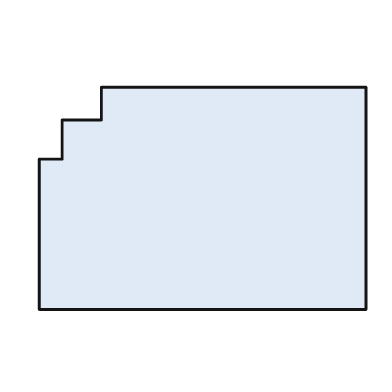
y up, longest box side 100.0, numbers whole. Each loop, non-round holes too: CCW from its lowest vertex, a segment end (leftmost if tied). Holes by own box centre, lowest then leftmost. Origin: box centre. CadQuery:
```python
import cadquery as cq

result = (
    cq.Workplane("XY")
    .moveTo(-50.0, -34.0)
    .lineTo(50.0, -34.0)
    .lineTo(50.0, 34.0)
    .lineTo(-31.0, 34.0)
    .lineTo(-31.0, 24.0)
    .lineTo(-43.0, 24.0)
    .lineTo(-43.0, 12.0)
    .lineTo(-50.0, 12.0)
    .close()
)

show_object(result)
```